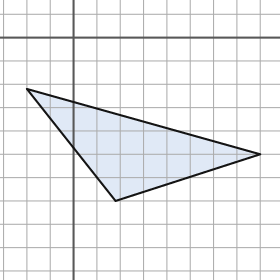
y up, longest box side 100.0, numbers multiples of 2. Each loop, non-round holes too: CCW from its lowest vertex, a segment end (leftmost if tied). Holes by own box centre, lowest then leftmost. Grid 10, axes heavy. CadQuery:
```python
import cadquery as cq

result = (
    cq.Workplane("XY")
    .moveTo(18.0, -70.0)
    .lineTo(80.0, -50.0)
    .lineTo(-20.0, -22.0)
    .close()
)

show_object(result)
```